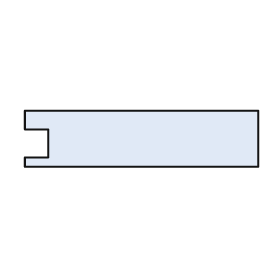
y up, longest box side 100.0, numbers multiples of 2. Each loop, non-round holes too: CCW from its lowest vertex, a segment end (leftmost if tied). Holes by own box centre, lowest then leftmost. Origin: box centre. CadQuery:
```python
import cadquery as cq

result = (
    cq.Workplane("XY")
    .moveTo(-50.0, -12.0)
    .lineTo(50.0, -12.0)
    .lineTo(50.0, 12.0)
    .lineTo(-50.0, 12.0)
    .lineTo(-50.0, 4.0)
    .lineTo(-40.0, 4.0)
    .lineTo(-40.0, -8.0)
    .lineTo(-50.0, -8.0)
    .close()
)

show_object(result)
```